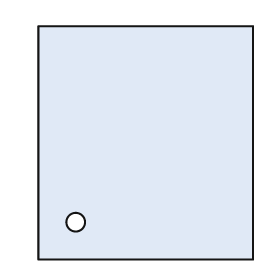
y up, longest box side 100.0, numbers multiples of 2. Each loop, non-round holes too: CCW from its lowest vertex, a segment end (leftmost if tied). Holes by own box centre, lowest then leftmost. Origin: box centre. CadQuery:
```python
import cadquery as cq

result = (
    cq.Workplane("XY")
    .moveTo(-46.0, -50.0)
    .lineTo(46.0, -50.0)
    .lineTo(46.0, 50.0)
    .lineTo(-46.0, 50.0)
    .close()
    .moveTo(-30.0, -34.0)
    .circle(4.0)
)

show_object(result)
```